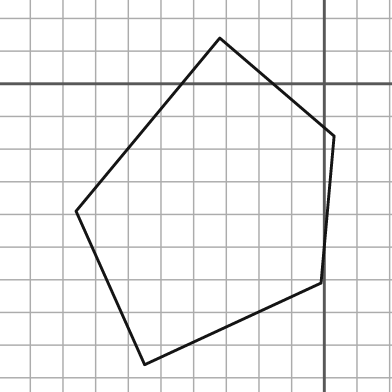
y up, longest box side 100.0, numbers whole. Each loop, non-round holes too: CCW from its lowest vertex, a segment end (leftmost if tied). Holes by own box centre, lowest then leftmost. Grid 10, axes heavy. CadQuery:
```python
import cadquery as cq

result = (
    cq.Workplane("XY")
    .moveTo(-55.0, -86.0)
    .lineTo(-1.0, -61.0)
    .lineTo(3.0, -16.0)
    .lineTo(-32.0, 14.0)
    .lineTo(-76.0, -39.0)
    .close()
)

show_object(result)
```